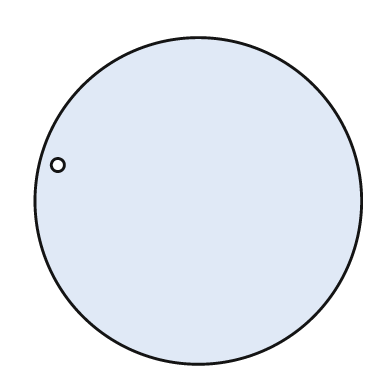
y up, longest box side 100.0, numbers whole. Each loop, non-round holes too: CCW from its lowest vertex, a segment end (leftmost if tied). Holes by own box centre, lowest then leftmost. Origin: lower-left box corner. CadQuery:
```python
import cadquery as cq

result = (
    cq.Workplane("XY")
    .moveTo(50.0, 50.0)
    .circle(50.0)
    .moveTo(7.0, 61.0)
    .circle(2.0)
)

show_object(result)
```